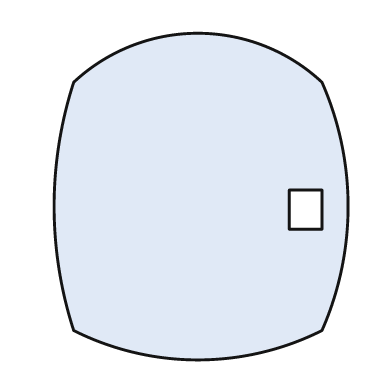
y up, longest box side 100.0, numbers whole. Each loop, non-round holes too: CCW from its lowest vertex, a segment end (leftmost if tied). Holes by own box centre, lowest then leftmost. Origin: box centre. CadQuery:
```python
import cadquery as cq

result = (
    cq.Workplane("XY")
    .moveTo(-39.0, -41.0)
    .threePointArc((-1.0, -50.0), (37.0, -41.0))
    .threePointArc((45.0, -3.0), (37.0, 35.0))
    .threePointArc((-1.0, 50.0), (-39.0, 35.0))
    .threePointArc((-45.0, -3.0), (-39.0, -41.0))
    .close()
    .moveTo(27.0, -10.0)
    .lineTo(37.0, -10.0)
    .lineTo(37.0, 2.0)
    .lineTo(27.0, 2.0)
    .close()
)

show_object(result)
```